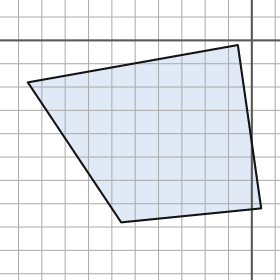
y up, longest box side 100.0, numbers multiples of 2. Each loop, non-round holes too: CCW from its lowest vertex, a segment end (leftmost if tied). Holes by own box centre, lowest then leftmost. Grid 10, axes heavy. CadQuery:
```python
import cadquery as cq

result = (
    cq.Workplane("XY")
    .moveTo(-56.0, -78.0)
    .lineTo(4.0, -72.0)
    .lineTo(-6.0, -2.0)
    .lineTo(-96.0, -18.0)
    .close()
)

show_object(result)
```